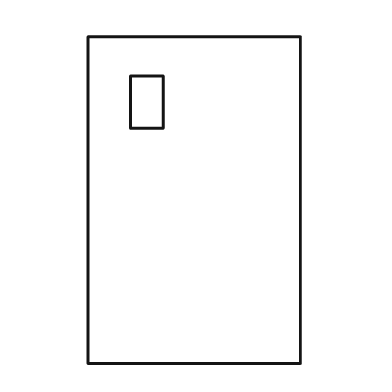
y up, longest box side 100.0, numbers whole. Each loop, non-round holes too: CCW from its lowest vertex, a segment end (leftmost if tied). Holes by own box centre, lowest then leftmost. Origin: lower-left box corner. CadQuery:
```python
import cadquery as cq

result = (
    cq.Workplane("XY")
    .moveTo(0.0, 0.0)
    .lineTo(65.0, 0.0)
    .lineTo(65.0, 100.0)
    .lineTo(0.0, 100.0)
    .close()
    .moveTo(13.0, 72.0)
    .lineTo(23.0, 72.0)
    .lineTo(23.0, 88.0)
    .lineTo(13.0, 88.0)
    .close()
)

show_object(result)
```